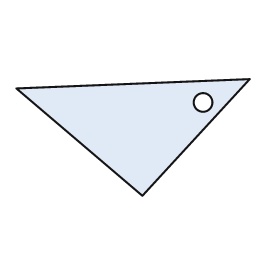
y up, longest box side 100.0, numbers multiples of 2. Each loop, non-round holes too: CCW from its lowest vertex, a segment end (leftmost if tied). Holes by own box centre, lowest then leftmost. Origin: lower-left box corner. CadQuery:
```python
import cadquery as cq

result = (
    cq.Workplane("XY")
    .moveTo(54.0, 0.0)
    .lineTo(100.0, 50.0)
    .lineTo(0.0, 46.0)
    .close()
    .moveTo(80.0, 40.0)
    .circle(4.0)
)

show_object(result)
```